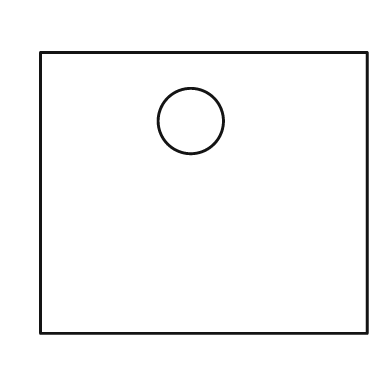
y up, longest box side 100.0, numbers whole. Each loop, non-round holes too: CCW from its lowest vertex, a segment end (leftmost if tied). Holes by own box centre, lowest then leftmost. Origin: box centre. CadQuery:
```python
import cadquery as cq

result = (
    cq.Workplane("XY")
    .moveTo(-50.0, -43.0)
    .lineTo(50.0, -43.0)
    .lineTo(50.0, 43.0)
    .lineTo(-50.0, 43.0)
    .close()
    .moveTo(-4.0, 22.0)
    .circle(10.0)
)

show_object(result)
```